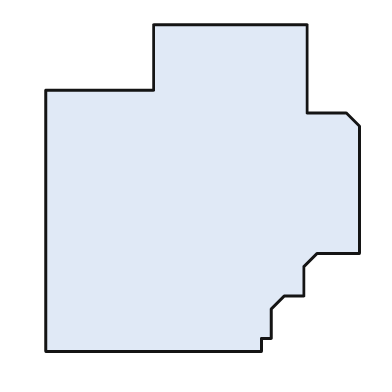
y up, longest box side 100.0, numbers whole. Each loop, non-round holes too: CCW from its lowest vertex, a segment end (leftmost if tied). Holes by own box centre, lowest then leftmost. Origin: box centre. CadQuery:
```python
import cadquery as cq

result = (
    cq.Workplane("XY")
    .moveTo(-48.0, -50.0)
    .lineTo(18.0, -50.0)
    .lineTo(18.0, -46.0)
    .lineTo(21.0, -46.0)
    .lineTo(21.0, -37.0)
    .lineTo(25.0, -33.0)
    .lineTo(31.0, -33.0)
    .lineTo(31.0, -24.0)
    .lineTo(35.0, -20.0)
    .lineTo(48.0, -20.0)
    .lineTo(48.0, 19.0)
    .lineTo(44.0, 23.0)
    .lineTo(32.0, 23.0)
    .lineTo(32.0, 50.0)
    .lineTo(-15.0, 50.0)
    .lineTo(-15.0, 30.0)
    .lineTo(-48.0, 30.0)
    .close()
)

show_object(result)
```